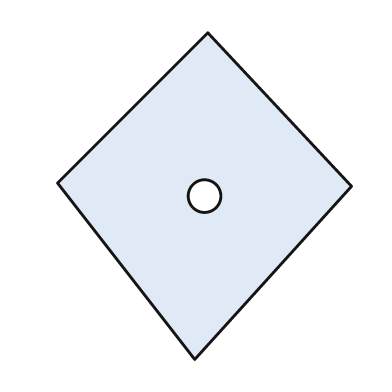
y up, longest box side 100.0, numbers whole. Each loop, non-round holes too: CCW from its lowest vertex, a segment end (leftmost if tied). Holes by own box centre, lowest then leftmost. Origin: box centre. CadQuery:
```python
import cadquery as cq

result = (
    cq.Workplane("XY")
    .moveTo(-3.0, -50.0)
    .lineTo(45.0, 3.0)
    .lineTo(1.0, 50.0)
    .lineTo(-45.0, 4.0)
    .close()
    .moveTo(0.0, 0.0)
    .circle(5.0)
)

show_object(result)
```